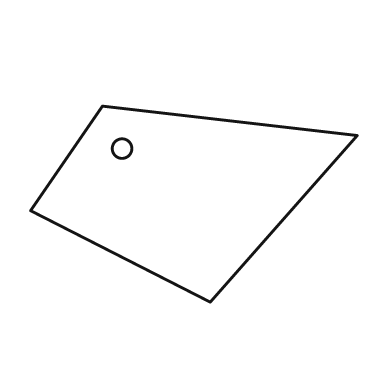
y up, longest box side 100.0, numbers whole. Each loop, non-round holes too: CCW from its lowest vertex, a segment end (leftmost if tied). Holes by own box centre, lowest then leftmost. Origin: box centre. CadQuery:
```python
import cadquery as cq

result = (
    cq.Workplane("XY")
    .moveTo(5.0, -30.0)
    .lineTo(50.0, 21.0)
    .lineTo(-28.0, 30.0)
    .lineTo(-50.0, -2.0)
    .close()
    .moveTo(-22.0, 17.0)
    .circle(3.0)
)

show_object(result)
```